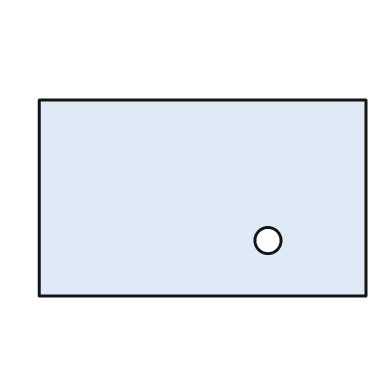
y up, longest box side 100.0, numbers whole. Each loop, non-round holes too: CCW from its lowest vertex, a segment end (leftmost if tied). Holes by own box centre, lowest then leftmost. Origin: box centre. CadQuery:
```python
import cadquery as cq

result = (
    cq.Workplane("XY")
    .moveTo(-50.0, -30.0)
    .lineTo(50.0, -30.0)
    .lineTo(50.0, 30.0)
    .lineTo(-50.0, 30.0)
    .close()
    .moveTo(20.0, -13.0)
    .circle(4.0)
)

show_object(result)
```